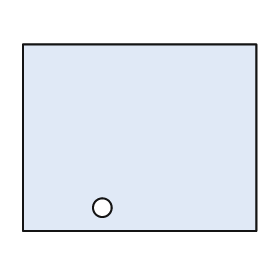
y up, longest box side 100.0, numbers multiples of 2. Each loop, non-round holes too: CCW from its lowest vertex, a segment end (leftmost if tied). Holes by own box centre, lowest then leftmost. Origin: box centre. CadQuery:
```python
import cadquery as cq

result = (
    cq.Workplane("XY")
    .moveTo(-50.0, -40.0)
    .lineTo(50.0, -40.0)
    .lineTo(50.0, 40.0)
    .lineTo(-50.0, 40.0)
    .close()
    .moveTo(-16.0, -30.0)
    .circle(4.0)
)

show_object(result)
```